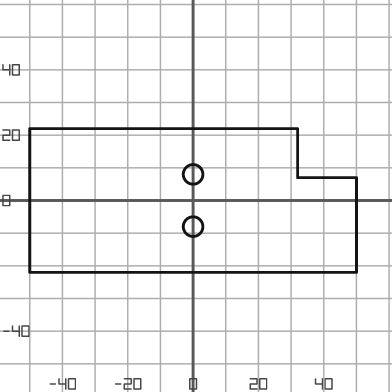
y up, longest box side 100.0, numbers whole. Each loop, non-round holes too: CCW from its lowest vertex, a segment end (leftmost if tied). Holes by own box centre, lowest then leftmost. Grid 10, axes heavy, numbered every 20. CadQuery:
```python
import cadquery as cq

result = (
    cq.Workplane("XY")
    .moveTo(-50.0, -22.0)
    .lineTo(50.0, -22.0)
    .lineTo(50.0, 7.0)
    .lineTo(32.0, 7.0)
    .lineTo(32.0, 22.0)
    .lineTo(-50.0, 22.0)
    .close()
    .moveTo(0.0, -8.0)
    .circle(3.0)
    .moveTo(0.0, 8.0)
    .circle(3.0)
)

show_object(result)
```